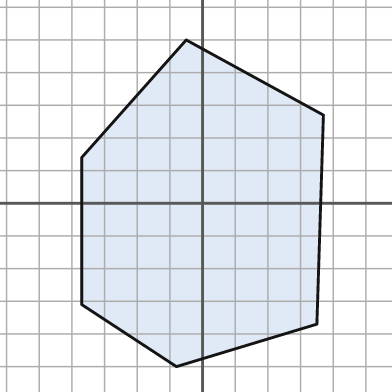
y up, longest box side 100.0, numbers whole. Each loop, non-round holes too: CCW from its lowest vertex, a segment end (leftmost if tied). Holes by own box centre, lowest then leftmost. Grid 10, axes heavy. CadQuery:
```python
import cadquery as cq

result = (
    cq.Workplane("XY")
    .moveTo(-8.0, -50.0)
    .lineTo(35.0, -37.0)
    .lineTo(37.0, 27.0)
    .lineTo(-5.0, 50.0)
    .lineTo(-37.0, 14.0)
    .lineTo(-37.0, -31.0)
    .close()
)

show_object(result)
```